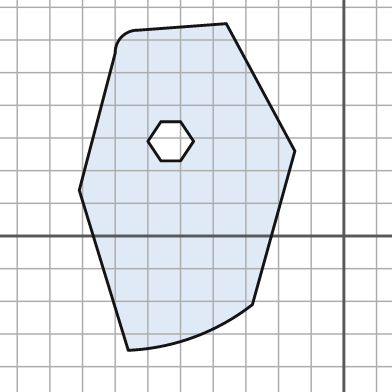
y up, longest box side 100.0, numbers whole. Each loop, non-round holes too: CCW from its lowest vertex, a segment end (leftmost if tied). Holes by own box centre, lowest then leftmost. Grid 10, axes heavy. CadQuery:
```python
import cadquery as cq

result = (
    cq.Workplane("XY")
    .moveTo(-66.0, -35.0)
    .threePointArc((-46.0, -31.0), (-28.0, -21.0))
    .lineTo(-15.0, 26.0)
    .lineTo(-36.0, 65.0)
    .lineTo(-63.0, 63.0)
    .threePointArc((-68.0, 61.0), (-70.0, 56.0))
    .lineTo(-81.0, 14.0)
    .close()
    .moveTo(-56.0, 23.0)
    .lineTo(-50.0, 23.0)
    .lineTo(-46.0, 29.0)
    .lineTo(-50.0, 35.0)
    .lineTo(-56.0, 35.0)
    .lineTo(-60.0, 29.0)
    .close()
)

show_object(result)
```